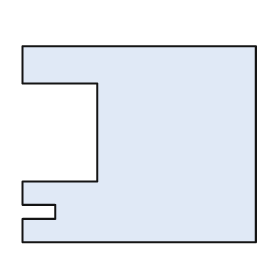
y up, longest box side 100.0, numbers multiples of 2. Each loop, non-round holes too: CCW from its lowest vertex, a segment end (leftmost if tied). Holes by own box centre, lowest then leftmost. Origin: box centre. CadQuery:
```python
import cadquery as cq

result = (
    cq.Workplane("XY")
    .moveTo(-50.0, -42.0)
    .lineTo(50.0, -42.0)
    .lineTo(50.0, 42.0)
    .lineTo(-50.0, 42.0)
    .lineTo(-50.0, 26.0)
    .lineTo(-18.0, 26.0)
    .lineTo(-18.0, -16.0)
    .lineTo(-50.0, -16.0)
    .lineTo(-50.0, -26.0)
    .lineTo(-36.0, -26.0)
    .lineTo(-36.0, -32.0)
    .lineTo(-50.0, -32.0)
    .close()
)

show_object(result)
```